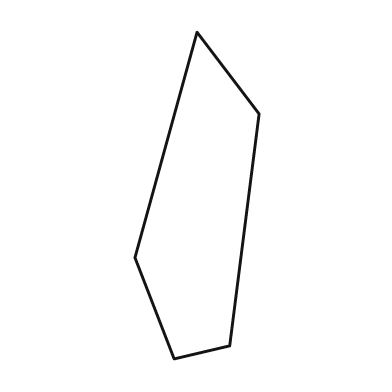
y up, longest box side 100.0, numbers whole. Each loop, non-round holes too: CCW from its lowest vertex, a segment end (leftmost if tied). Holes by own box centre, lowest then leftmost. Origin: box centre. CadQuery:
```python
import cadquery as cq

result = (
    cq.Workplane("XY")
    .moveTo(-7.0, -50.0)
    .lineTo(10.0, -46.0)
    .lineTo(19.0, 25.0)
    .lineTo(0.0, 50.0)
    .lineTo(-19.0, -19.0)
    .close()
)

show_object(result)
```